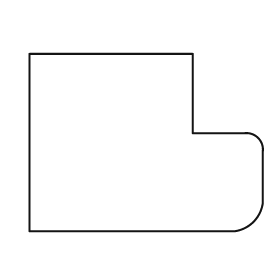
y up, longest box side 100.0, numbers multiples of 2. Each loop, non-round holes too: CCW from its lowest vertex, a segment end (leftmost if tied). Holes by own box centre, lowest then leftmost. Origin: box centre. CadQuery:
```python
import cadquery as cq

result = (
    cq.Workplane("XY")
    .moveTo(-50.0, -38.0)
    .lineTo(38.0, -38.0)
    .threePointArc((46.0, -34.0), (50.0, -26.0))
    .lineTo(50.0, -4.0)
    .threePointArc((48.0, 2.0), (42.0, 4.0))
    .lineTo(20.0, 4.0)
    .lineTo(20.0, 38.0)
    .lineTo(-50.0, 38.0)
    .close()
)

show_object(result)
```